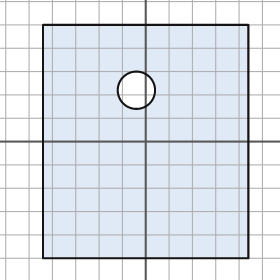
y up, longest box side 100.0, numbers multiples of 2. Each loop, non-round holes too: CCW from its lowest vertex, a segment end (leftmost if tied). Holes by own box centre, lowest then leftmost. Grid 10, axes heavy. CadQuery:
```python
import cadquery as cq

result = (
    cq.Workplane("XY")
    .moveTo(-44.0, -50.0)
    .lineTo(44.0, -50.0)
    .lineTo(44.0, 50.0)
    .lineTo(-44.0, 50.0)
    .close()
    .moveTo(-4.0, 22.0)
    .circle(8.0)
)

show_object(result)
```